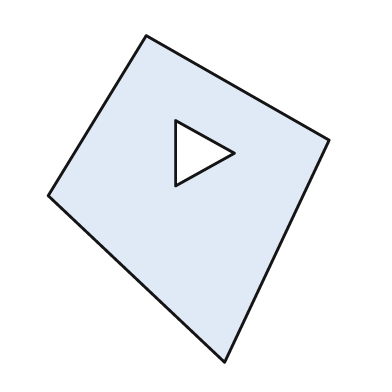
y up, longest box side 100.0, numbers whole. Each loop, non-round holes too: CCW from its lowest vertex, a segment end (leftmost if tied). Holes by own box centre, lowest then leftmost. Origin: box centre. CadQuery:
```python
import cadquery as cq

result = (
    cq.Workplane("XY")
    .moveTo(11.0, -50.0)
    .lineTo(43.0, 18.0)
    .lineTo(-13.0, 50.0)
    .lineTo(-43.0, 1.0)
    .close()
    .moveTo(-4.0, 4.0)
    .lineTo(14.0, 14.0)
    .lineTo(-4.0, 24.0)
    .close()
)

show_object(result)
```